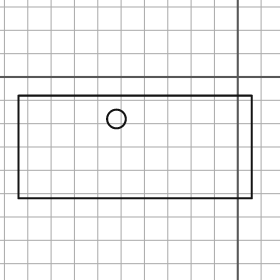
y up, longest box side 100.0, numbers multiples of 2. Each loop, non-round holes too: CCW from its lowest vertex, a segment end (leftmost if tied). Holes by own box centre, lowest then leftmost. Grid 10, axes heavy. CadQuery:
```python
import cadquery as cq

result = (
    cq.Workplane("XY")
    .moveTo(-94.0, -52.0)
    .lineTo(6.0, -52.0)
    .lineTo(6.0, -8.0)
    .lineTo(-94.0, -8.0)
    .close()
    .moveTo(-52.0, -18.0)
    .circle(4.0)
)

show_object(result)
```